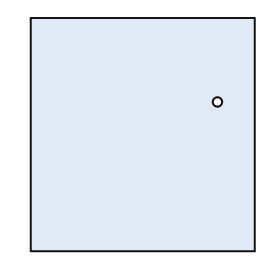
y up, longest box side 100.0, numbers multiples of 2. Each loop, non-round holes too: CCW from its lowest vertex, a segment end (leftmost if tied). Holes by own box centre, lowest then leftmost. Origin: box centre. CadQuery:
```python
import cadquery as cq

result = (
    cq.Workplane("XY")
    .moveTo(-48.0, -50.0)
    .lineTo(48.0, -50.0)
    .lineTo(48.0, 50.0)
    .lineTo(-48.0, 50.0)
    .close()
    .moveTo(32.0, 14.0)
    .circle(2.0)
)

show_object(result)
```